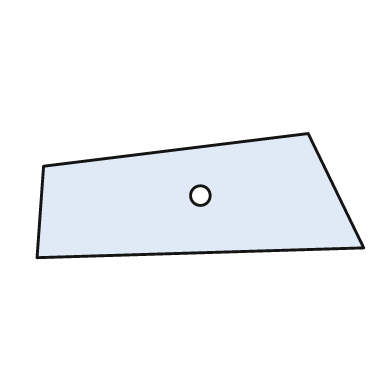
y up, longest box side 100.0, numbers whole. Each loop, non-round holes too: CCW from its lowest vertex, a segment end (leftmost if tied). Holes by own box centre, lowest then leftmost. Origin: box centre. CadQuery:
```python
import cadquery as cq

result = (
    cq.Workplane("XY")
    .moveTo(-50.0, -19.0)
    .lineTo(50.0, -16.0)
    .lineTo(33.0, 19.0)
    .lineTo(-48.0, 9.0)
    .close()
    .moveTo(0.0, 0.0)
    .circle(3.0)
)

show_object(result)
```